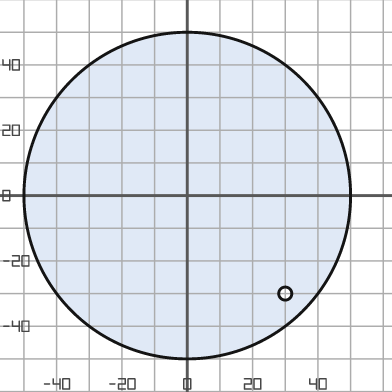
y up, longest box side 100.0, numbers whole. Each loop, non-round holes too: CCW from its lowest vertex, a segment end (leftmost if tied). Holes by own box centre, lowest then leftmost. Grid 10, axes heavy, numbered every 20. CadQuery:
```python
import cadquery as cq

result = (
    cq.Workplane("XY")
    .moveTo(0.0, 0.0)
    .circle(50.0)
    .moveTo(30.0, -30.0)
    .circle(2.0)
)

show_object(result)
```